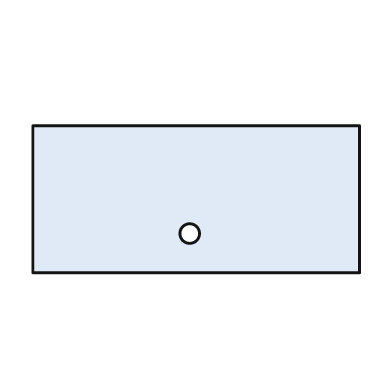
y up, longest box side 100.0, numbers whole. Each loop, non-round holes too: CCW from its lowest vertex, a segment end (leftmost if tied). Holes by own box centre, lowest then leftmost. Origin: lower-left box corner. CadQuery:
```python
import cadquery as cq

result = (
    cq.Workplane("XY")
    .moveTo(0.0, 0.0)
    .lineTo(100.0, 0.0)
    .lineTo(100.0, 45.0)
    .lineTo(0.0, 45.0)
    .close()
    .moveTo(48.0, 12.0)
    .circle(3.0)
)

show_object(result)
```